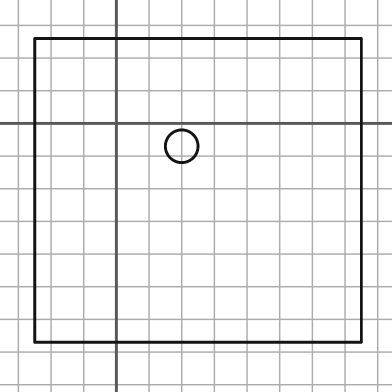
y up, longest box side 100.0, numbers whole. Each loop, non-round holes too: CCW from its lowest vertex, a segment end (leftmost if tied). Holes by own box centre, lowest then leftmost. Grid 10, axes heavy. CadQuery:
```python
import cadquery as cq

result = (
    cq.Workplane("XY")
    .moveTo(-25.0, -67.0)
    .lineTo(75.0, -67.0)
    .lineTo(75.0, 26.0)
    .lineTo(-25.0, 26.0)
    .close()
    .moveTo(20.0, -7.0)
    .circle(5.0)
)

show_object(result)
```